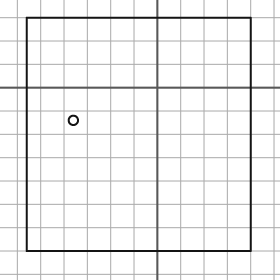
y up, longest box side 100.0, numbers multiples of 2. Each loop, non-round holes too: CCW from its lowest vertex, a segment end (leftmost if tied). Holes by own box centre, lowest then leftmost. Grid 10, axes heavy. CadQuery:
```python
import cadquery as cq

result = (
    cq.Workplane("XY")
    .moveTo(-56.0, -70.0)
    .lineTo(40.0, -70.0)
    .lineTo(40.0, 30.0)
    .lineTo(-56.0, 30.0)
    .close()
    .moveTo(-36.0, -14.0)
    .circle(2.0)
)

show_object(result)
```